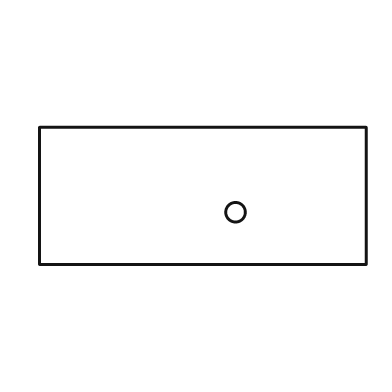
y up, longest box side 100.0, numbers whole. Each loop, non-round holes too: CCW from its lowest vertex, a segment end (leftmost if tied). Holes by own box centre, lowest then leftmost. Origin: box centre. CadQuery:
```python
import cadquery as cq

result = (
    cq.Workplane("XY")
    .moveTo(-50.0, -21.0)
    .lineTo(50.0, -21.0)
    .lineTo(50.0, 21.0)
    .lineTo(-50.0, 21.0)
    .close()
    .moveTo(10.0, -5.0)
    .circle(3.0)
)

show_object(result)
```